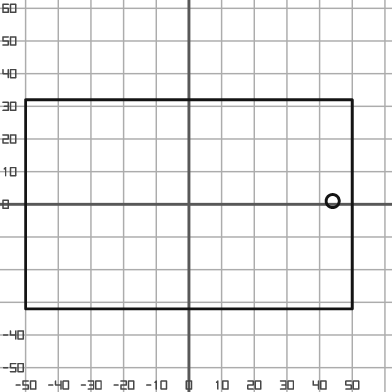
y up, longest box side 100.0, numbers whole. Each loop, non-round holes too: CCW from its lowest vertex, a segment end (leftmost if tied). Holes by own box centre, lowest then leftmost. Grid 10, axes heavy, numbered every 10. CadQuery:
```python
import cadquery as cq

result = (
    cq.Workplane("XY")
    .moveTo(-50.0, -32.0)
    .lineTo(50.0, -32.0)
    .lineTo(50.0, 32.0)
    .lineTo(-50.0, 32.0)
    .close()
    .moveTo(44.0, 1.0)
    .circle(2.0)
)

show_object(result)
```